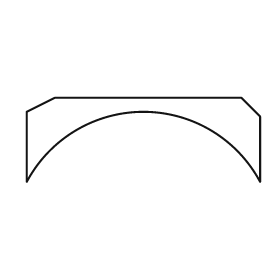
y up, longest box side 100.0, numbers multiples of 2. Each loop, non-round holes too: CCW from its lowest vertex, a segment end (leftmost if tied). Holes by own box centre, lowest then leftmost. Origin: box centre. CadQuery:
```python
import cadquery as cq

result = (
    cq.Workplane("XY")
    .moveTo(-50.0, -18.0)
    .threePointArc((0.0, 12.0), (50.0, -18.0))
    .lineTo(50.0, 10.0)
    .lineTo(42.0, 18.0)
    .lineTo(-38.0, 18.0)
    .lineTo(-50.0, 12.0)
    .close()
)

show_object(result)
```